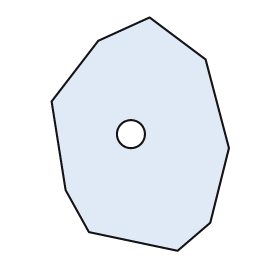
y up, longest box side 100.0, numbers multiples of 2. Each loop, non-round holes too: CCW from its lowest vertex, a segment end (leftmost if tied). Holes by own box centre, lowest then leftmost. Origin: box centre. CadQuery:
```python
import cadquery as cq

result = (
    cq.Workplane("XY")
    .moveTo(16.0, -50.0)
    .lineTo(30.0, -38.0)
    .lineTo(38.0, -6.0)
    .lineTo(28.0, 32.0)
    .lineTo(4.0, 50.0)
    .lineTo(-18.0, 40.0)
    .lineTo(-38.0, 14.0)
    .lineTo(-32.0, -24.0)
    .lineTo(-22.0, -42.0)
    .close()
    .moveTo(-4.0, 0.0)
    .circle(6.0)
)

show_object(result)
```